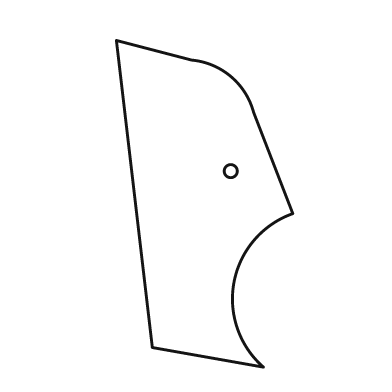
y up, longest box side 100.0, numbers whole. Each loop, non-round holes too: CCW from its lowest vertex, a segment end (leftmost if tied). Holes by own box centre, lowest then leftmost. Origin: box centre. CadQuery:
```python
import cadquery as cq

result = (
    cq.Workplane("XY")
    .moveTo(18.0, -50.0)
    .threePointArc((9.0, -24.0), (27.0, -3.0))
    .lineTo(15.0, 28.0)
    .threePointArc((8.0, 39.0), (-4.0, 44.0))
    .lineTo(-27.0, 50.0)
    .lineTo(-16.0, -44.0)
    .close()
    .moveTo(8.0, 10.0)
    .circle(2.0)
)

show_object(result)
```